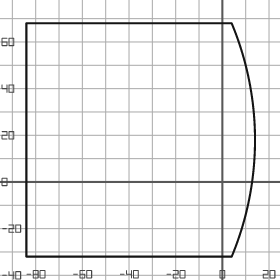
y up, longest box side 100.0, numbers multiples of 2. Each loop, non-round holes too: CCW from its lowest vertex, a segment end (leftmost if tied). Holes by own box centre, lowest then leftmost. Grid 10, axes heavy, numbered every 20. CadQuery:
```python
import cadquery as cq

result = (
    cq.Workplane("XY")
    .moveTo(-84.0, -32.0)
    .lineTo(4.0, -32.0)
    .threePointArc((14.0, 18.0), (4.0, 68.0))
    .lineTo(-84.0, 68.0)
    .close()
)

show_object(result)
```